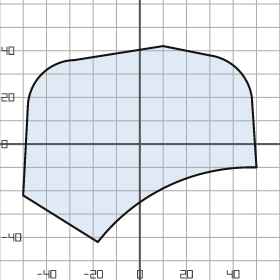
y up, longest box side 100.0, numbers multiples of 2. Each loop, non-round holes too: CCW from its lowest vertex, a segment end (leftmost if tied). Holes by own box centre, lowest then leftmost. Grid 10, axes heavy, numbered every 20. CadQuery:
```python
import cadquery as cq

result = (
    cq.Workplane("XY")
    .moveTo(-18.0, -42.0)
    .threePointArc((12.0, -18.0), (50.0, -10.0))
    .lineTo(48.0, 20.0)
    .threePointArc((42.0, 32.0), (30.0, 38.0))
    .lineTo(10.0, 42.0)
    .lineTo(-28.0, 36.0)
    .threePointArc((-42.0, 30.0), (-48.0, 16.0))
    .lineTo(-50.0, -22.0)
    .close()
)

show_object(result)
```